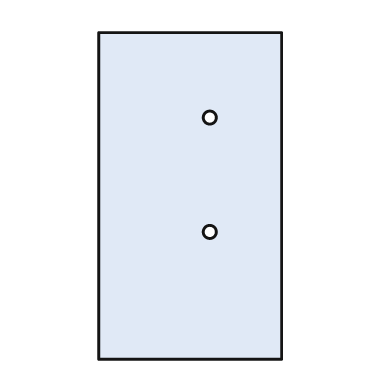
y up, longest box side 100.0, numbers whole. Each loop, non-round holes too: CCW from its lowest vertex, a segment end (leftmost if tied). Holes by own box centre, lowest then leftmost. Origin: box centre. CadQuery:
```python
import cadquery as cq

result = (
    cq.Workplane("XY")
    .moveTo(-28.0, -50.0)
    .lineTo(28.0, -50.0)
    .lineTo(28.0, 50.0)
    .lineTo(-28.0, 50.0)
    .close()
    .moveTo(6.0, -11.0)
    .circle(2.0)
    .moveTo(6.0, 24.0)
    .circle(2.0)
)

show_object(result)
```